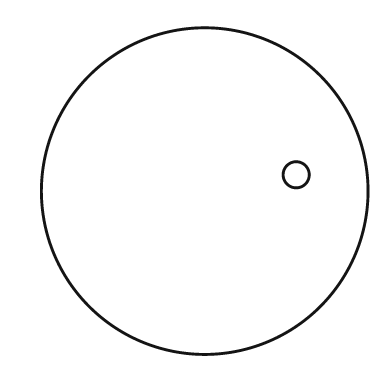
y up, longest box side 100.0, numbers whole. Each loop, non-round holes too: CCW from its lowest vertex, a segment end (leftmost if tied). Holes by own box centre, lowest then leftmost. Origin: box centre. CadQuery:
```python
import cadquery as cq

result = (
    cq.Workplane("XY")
    .moveTo(0.0, 0.0)
    .circle(50.0)
    .moveTo(28.0, 5.0)
    .circle(4.0)
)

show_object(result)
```